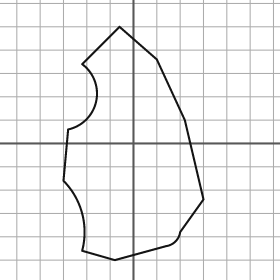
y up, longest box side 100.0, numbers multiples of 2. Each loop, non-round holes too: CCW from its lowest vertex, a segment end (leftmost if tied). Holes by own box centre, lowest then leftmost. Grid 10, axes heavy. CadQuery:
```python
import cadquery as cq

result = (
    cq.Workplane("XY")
    .moveTo(-8.0, -50.0)
    .lineTo(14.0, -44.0)
    .threePointArc((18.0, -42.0), (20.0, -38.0))
    .lineTo(30.0, -24.0)
    .lineTo(22.0, 10.0)
    .lineTo(10.0, 36.0)
    .lineTo(-6.0, 50.0)
    .lineTo(-22.0, 34.0)
    .threePointArc((-16.0, 18.0), (-28.0, 6.0))
    .lineTo(-30.0, -16.0)
    .threePointArc((-22.0, -30.0), (-22.0, -46.0))
    .close()
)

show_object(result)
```